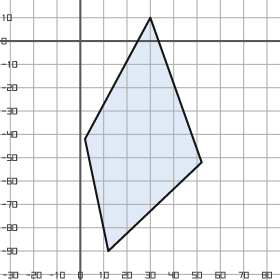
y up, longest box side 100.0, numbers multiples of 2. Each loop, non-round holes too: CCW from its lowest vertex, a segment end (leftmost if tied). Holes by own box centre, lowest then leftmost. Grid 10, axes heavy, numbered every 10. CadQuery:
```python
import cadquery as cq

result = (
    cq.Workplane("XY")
    .moveTo(12.0, -90.0)
    .lineTo(52.0, -52.0)
    .lineTo(30.0, 10.0)
    .lineTo(2.0, -42.0)
    .close()
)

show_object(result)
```